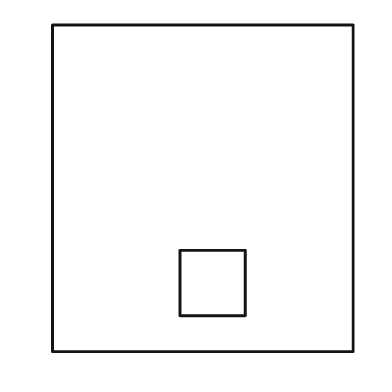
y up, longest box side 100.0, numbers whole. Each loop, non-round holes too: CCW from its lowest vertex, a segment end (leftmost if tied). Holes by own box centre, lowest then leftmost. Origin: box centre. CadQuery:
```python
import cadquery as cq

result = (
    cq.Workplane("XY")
    .moveTo(-46.0, -50.0)
    .lineTo(46.0, -50.0)
    .lineTo(46.0, 50.0)
    .lineTo(-46.0, 50.0)
    .close()
    .moveTo(-7.0, -39.0)
    .lineTo(13.0, -39.0)
    .lineTo(13.0, -19.0)
    .lineTo(-7.0, -19.0)
    .close()
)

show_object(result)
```